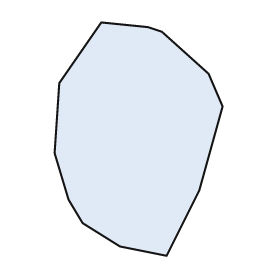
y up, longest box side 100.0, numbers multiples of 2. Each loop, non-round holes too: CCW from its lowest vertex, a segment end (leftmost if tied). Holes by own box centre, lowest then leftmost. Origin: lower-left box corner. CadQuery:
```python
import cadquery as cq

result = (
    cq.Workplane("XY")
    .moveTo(48.0, 0.0)
    .lineTo(62.0, 28.0)
    .lineTo(72.0, 64.0)
    .lineTo(66.0, 78.0)
    .lineTo(46.0, 96.0)
    .lineTo(40.0, 98.0)
    .lineTo(20.0, 100.0)
    .lineTo(2.0, 74.0)
    .lineTo(0.0, 44.0)
    .lineTo(6.0, 24.0)
    .lineTo(12.0, 14.0)
    .lineTo(28.0, 4.0)
    .close()
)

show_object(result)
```